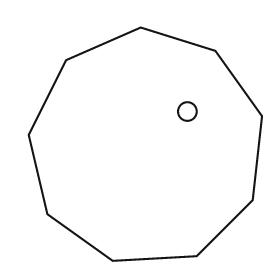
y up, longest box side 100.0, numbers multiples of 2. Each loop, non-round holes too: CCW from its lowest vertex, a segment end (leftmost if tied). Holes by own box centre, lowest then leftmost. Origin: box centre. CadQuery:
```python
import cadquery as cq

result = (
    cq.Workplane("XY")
    .moveTo(-14.0, -50.0)
    .lineTo(22.0, -48.0)
    .lineTo(46.0, -24.0)
    .lineTo(50.0, 12.0)
    .lineTo(30.0, 40.0)
    .lineTo(-2.0, 50.0)
    .lineTo(-34.0, 36.0)
    .lineTo(-50.0, 4.0)
    .lineTo(-42.0, -30.0)
    .close()
    .moveTo(18.0, 14.0)
    .circle(4.0)
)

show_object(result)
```